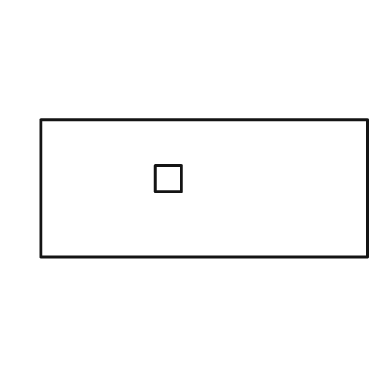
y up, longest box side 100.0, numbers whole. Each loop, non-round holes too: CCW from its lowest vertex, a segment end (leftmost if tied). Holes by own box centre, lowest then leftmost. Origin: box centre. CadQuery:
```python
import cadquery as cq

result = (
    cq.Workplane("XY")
    .moveTo(-50.0, -21.0)
    .lineTo(50.0, -21.0)
    .lineTo(50.0, 21.0)
    .lineTo(-50.0, 21.0)
    .close()
    .moveTo(-15.0, -1.0)
    .lineTo(-7.0, -1.0)
    .lineTo(-7.0, 7.0)
    .lineTo(-15.0, 7.0)
    .close()
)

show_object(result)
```